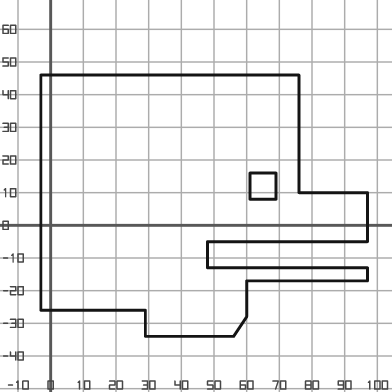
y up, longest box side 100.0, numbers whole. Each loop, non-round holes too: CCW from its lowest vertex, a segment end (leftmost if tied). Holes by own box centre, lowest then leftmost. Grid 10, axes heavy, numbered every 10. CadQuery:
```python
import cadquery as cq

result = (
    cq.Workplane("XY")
    .moveTo(29.0, -34.0)
    .lineTo(56.0, -34.0)
    .lineTo(60.0, -28.0)
    .lineTo(60.0, -17.0)
    .lineTo(97.0, -17.0)
    .lineTo(97.0, -13.0)
    .lineTo(48.0, -13.0)
    .lineTo(48.0, -5.0)
    .lineTo(97.0, -5.0)
    .lineTo(97.0, 10.0)
    .lineTo(76.0, 10.0)
    .lineTo(76.0, 46.0)
    .lineTo(-3.0, 46.0)
    .lineTo(-3.0, -26.0)
    .lineTo(29.0, -26.0)
    .close()
    .moveTo(61.0, 8.0)
    .lineTo(69.0, 8.0)
    .lineTo(69.0, 16.0)
    .lineTo(61.0, 16.0)
    .close()
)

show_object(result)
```